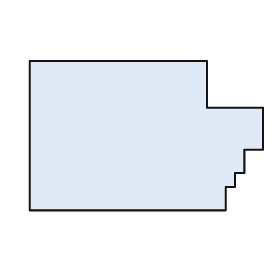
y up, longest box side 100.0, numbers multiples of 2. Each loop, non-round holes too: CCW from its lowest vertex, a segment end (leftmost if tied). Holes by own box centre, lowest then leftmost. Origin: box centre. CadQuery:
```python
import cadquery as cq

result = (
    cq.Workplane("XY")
    .moveTo(-50.0, -32.0)
    .lineTo(34.0, -32.0)
    .lineTo(34.0, -22.0)
    .lineTo(38.0, -22.0)
    .lineTo(38.0, -16.0)
    .lineTo(42.0, -16.0)
    .lineTo(42.0, -6.0)
    .lineTo(50.0, -6.0)
    .lineTo(50.0, 12.0)
    .lineTo(26.0, 12.0)
    .lineTo(26.0, 32.0)
    .lineTo(-50.0, 32.0)
    .close()
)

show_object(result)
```